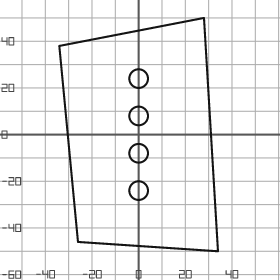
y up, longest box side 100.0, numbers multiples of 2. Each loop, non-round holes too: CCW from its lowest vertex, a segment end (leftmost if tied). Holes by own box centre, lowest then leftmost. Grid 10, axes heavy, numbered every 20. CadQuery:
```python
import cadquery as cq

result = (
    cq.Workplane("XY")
    .moveTo(34.0, -50.0)
    .lineTo(28.0, 50.0)
    .lineTo(-34.0, 38.0)
    .lineTo(-26.0, -46.0)
    .close()
    .moveTo(0.0, -24.0)
    .circle(4.0)
    .moveTo(0.0, -8.0)
    .circle(4.0)
    .moveTo(0.0, 8.0)
    .circle(4.0)
    .moveTo(0.0, 24.0)
    .circle(4.0)
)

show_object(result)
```